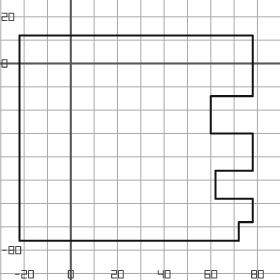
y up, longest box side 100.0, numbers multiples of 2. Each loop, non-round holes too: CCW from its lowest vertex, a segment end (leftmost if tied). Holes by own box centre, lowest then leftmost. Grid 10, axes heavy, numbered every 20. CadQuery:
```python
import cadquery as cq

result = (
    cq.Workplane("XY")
    .moveTo(-22.0, -76.0)
    .lineTo(72.0, -76.0)
    .lineTo(72.0, -68.0)
    .lineTo(78.0, -68.0)
    .lineTo(78.0, -58.0)
    .lineTo(62.0, -58.0)
    .lineTo(62.0, -46.0)
    .lineTo(78.0, -46.0)
    .lineTo(78.0, -30.0)
    .lineTo(60.0, -30.0)
    .lineTo(60.0, -14.0)
    .lineTo(78.0, -14.0)
    .lineTo(78.0, 12.0)
    .lineTo(-22.0, 12.0)
    .close()
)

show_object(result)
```